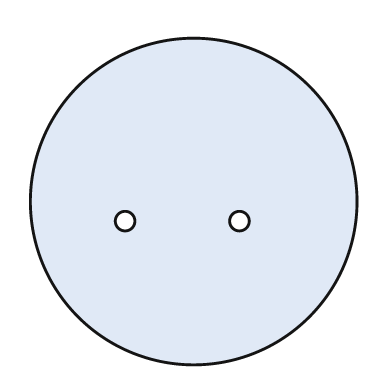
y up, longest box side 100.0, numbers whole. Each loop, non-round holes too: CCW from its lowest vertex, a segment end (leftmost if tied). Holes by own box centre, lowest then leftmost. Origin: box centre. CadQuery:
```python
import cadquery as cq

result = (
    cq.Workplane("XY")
    .moveTo(0.0, 0.0)
    .circle(50.0)
    .moveTo(-21.0, -6.0)
    .circle(3.0)
    .moveTo(14.0, -6.0)
    .circle(3.0)
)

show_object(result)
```